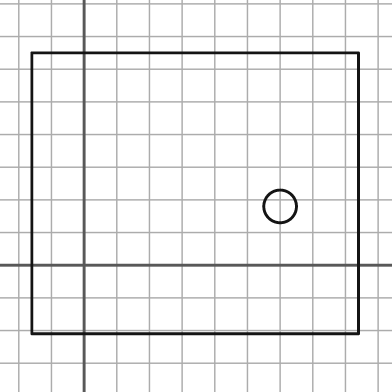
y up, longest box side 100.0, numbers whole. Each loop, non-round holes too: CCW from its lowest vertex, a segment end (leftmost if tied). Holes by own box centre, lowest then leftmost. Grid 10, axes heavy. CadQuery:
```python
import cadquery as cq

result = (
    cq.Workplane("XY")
    .moveTo(-16.0, -21.0)
    .lineTo(84.0, -21.0)
    .lineTo(84.0, 65.0)
    .lineTo(-16.0, 65.0)
    .close()
    .moveTo(60.0, 18.0)
    .circle(5.0)
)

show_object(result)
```